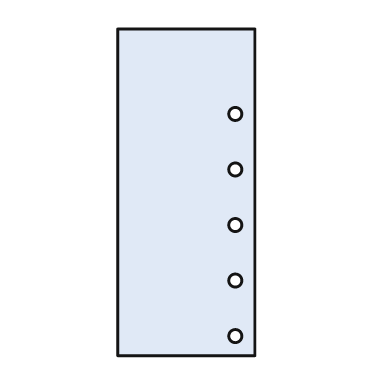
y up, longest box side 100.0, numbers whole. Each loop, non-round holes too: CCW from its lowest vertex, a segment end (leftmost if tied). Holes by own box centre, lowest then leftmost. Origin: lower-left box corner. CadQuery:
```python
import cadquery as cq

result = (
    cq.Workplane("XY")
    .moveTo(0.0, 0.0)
    .lineTo(42.0, 0.0)
    .lineTo(42.0, 100.0)
    .lineTo(0.0, 100.0)
    .close()
    .moveTo(36.0, 6.0)
    .circle(2.0)
    .moveTo(36.0, 23.0)
    .circle(2.0)
    .moveTo(36.0, 40.0)
    .circle(2.0)
    .moveTo(36.0, 57.0)
    .circle(2.0)
    .moveTo(36.0, 74.0)
    .circle(2.0)
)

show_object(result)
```